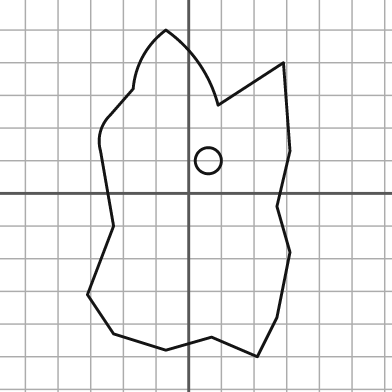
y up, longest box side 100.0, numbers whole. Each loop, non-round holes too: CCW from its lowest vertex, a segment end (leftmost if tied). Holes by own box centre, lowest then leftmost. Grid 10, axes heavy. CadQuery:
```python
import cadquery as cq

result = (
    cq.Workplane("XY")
    .moveTo(21.0, -50.0)
    .lineTo(27.0, -38.0)
    .lineTo(31.0, -18.0)
    .lineTo(27.0, -4.0)
    .lineTo(31.0, 13.0)
    .lineTo(29.0, 40.0)
    .lineTo(9.0, 27.0)
    .threePointArc((3.0, 40.0), (-7.0, 50.0))
    .threePointArc((-14.0, 42.0), (-17.0, 32.0))
    .lineTo(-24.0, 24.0)
    .threePointArc((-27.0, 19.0), (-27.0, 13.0))
    .lineTo(-23.0, -10.0)
    .lineTo(-31.0, -31.0)
    .lineTo(-23.0, -43.0)
    .lineTo(-7.0, -48.0)
    .lineTo(7.0, -44.0)
    .close()
    .moveTo(6.0, 10.0)
    .circle(4.0)
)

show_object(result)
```